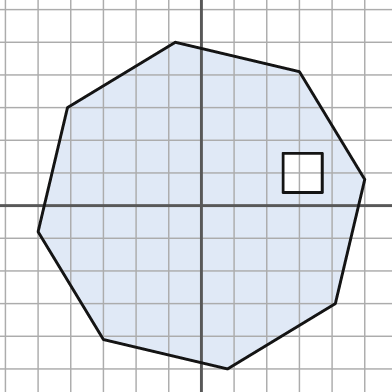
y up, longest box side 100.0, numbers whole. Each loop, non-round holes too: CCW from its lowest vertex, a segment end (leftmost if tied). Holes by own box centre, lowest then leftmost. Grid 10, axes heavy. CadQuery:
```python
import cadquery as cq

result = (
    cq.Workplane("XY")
    .moveTo(8.0, -50.0)
    .lineTo(41.0, -30.0)
    .lineTo(50.0, 8.0)
    .lineTo(30.0, 41.0)
    .lineTo(-8.0, 50.0)
    .lineTo(-41.0, 30.0)
    .lineTo(-50.0, -8.0)
    .lineTo(-30.0, -41.0)
    .close()
    .moveTo(25.0, 4.0)
    .lineTo(37.0, 4.0)
    .lineTo(37.0, 16.0)
    .lineTo(25.0, 16.0)
    .close()
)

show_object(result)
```